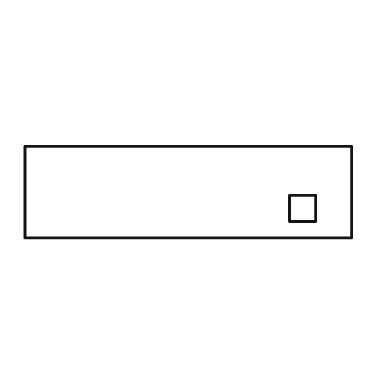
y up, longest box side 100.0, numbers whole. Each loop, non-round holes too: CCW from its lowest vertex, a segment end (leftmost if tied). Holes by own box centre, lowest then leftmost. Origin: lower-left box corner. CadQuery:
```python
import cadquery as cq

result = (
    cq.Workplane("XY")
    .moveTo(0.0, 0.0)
    .lineTo(100.0, 0.0)
    .lineTo(100.0, 28.0)
    .lineTo(0.0, 28.0)
    .close()
    .moveTo(81.0, 5.0)
    .lineTo(89.0, 5.0)
    .lineTo(89.0, 13.0)
    .lineTo(81.0, 13.0)
    .close()
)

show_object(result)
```